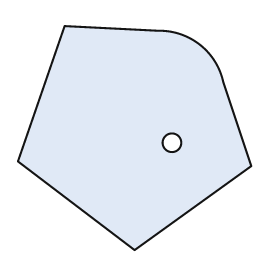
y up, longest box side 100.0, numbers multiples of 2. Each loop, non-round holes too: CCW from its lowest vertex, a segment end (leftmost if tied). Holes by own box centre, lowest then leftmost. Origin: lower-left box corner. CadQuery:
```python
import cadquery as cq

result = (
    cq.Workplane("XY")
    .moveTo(50.0, 0.0)
    .lineTo(100.0, 36.0)
    .lineTo(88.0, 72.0)
    .threePointArc((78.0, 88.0), (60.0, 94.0))
    .lineTo(20.0, 96.0)
    .lineTo(0.0, 38.0)
    .close()
    .moveTo(66.0, 46.0)
    .circle(4.0)
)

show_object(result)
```